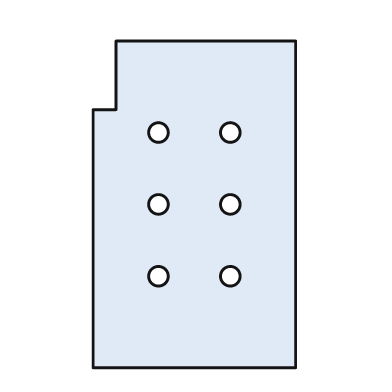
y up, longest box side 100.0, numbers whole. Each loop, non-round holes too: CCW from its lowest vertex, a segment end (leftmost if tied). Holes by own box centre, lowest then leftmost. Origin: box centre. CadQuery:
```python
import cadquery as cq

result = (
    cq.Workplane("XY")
    .moveTo(-31.0, -50.0)
    .lineTo(31.0, -50.0)
    .lineTo(31.0, 50.0)
    .lineTo(-24.0, 50.0)
    .lineTo(-24.0, 29.0)
    .lineTo(-31.0, 29.0)
    .close()
    .moveTo(-11.0, -22.0)
    .circle(3.0)
    .moveTo(11.0, -22.0)
    .circle(3.0)
    .moveTo(-11.0, 0.0)
    .circle(3.0)
    .moveTo(11.0, 0.0)
    .circle(3.0)
    .moveTo(-11.0, 22.0)
    .circle(3.0)
    .moveTo(11.0, 22.0)
    .circle(3.0)
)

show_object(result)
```